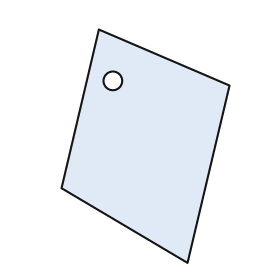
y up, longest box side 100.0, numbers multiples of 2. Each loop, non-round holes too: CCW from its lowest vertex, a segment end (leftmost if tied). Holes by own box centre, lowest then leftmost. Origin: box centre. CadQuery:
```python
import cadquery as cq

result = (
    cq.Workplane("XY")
    .moveTo(18.0, -50.0)
    .lineTo(36.0, 26.0)
    .lineTo(-20.0, 50.0)
    .lineTo(-36.0, -18.0)
    .close()
    .moveTo(-14.0, 28.0)
    .circle(4.0)
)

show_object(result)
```